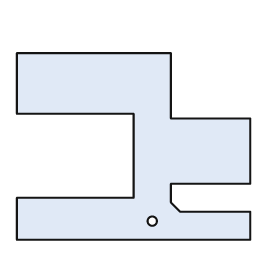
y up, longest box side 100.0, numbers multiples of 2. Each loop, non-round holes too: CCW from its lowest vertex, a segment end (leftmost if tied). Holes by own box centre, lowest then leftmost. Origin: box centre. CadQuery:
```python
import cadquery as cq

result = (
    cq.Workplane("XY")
    .moveTo(-50.0, -40.0)
    .lineTo(50.0, -40.0)
    .lineTo(50.0, -28.0)
    .lineTo(20.0, -28.0)
    .lineTo(16.0, -24.0)
    .lineTo(16.0, -16.0)
    .lineTo(50.0, -16.0)
    .lineTo(50.0, 12.0)
    .lineTo(16.0, 12.0)
    .lineTo(16.0, 40.0)
    .lineTo(-50.0, 40.0)
    .lineTo(-50.0, 14.0)
    .lineTo(0.0, 14.0)
    .lineTo(0.0, -22.0)
    .lineTo(-50.0, -22.0)
    .close()
    .moveTo(8.0, -32.0)
    .circle(2.0)
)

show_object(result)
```